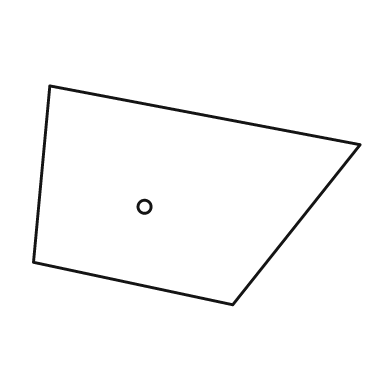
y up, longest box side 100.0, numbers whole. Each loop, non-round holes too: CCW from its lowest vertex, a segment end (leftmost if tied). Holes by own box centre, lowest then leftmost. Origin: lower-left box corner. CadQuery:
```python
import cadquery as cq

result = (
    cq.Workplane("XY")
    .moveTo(61.0, 0.0)
    .lineTo(100.0, 49.0)
    .lineTo(5.0, 67.0)
    .lineTo(0.0, 13.0)
    .close()
    .moveTo(34.0, 30.0)
    .circle(2.0)
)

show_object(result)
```